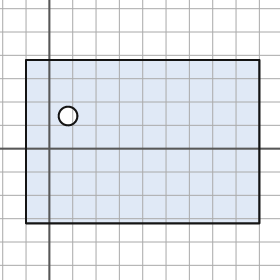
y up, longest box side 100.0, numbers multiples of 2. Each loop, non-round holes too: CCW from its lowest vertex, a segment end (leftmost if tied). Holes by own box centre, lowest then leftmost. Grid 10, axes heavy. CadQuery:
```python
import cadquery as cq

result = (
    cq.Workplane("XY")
    .moveTo(-10.0, -32.0)
    .lineTo(90.0, -32.0)
    .lineTo(90.0, 38.0)
    .lineTo(-10.0, 38.0)
    .close()
    .moveTo(8.0, 14.0)
    .circle(4.0)
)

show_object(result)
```